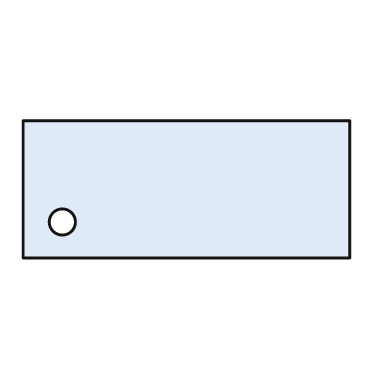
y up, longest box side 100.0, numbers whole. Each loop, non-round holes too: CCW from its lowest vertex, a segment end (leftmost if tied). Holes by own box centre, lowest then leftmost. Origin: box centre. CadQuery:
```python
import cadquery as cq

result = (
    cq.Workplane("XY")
    .moveTo(-50.0, -21.0)
    .lineTo(50.0, -21.0)
    .lineTo(50.0, 21.0)
    .lineTo(-50.0, 21.0)
    .close()
    .moveTo(-38.0, -10.0)
    .circle(4.0)
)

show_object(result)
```